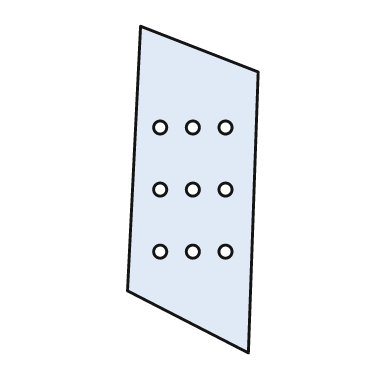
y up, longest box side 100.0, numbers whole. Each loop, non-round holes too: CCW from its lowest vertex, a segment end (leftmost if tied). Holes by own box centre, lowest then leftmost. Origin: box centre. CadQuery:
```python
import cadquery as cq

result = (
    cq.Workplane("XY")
    .moveTo(17.0, -50.0)
    .lineTo(20.0, 36.0)
    .lineTo(-16.0, 50.0)
    .lineTo(-20.0, -31.0)
    .close()
    .moveTo(-10.0, -19.0)
    .circle(2.0)
    .moveTo(0.0, -19.0)
    .circle(2.0)
    .moveTo(10.0, -19.0)
    .circle(2.0)
    .moveTo(-10.0, 0.0)
    .circle(2.0)
    .moveTo(0.0, 0.0)
    .circle(2.0)
    .moveTo(10.0, 0.0)
    .circle(2.0)
    .moveTo(-10.0, 19.0)
    .circle(2.0)
    .moveTo(0.0, 19.0)
    .circle(2.0)
    .moveTo(10.0, 19.0)
    .circle(2.0)
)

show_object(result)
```